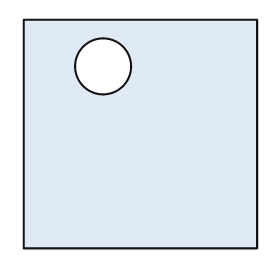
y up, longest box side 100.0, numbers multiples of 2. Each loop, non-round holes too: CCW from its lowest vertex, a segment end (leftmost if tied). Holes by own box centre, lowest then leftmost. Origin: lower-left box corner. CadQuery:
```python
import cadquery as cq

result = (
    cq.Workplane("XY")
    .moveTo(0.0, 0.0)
    .lineTo(100.0, 0.0)
    .lineTo(100.0, 98.0)
    .lineTo(0.0, 98.0)
    .close()
    .moveTo(34.0, 78.0)
    .circle(12.0)
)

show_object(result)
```